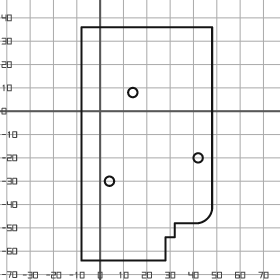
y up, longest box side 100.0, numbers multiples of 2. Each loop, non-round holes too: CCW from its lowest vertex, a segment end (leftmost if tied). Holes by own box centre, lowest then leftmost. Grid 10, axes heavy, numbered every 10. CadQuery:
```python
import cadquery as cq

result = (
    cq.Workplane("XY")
    .moveTo(-8.0, -64.0)
    .lineTo(28.0, -64.0)
    .lineTo(28.0, -54.0)
    .lineTo(32.0, -54.0)
    .lineTo(32.0, -48.0)
    .lineTo(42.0, -48.0)
    .threePointArc((46.0, -46.0), (48.0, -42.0))
    .lineTo(48.0, 36.0)
    .lineTo(-8.0, 36.0)
    .close()
    .moveTo(4.0, -30.0)
    .circle(2.0)
    .moveTo(42.0, -20.0)
    .circle(2.0)
    .moveTo(14.0, 8.0)
    .circle(2.0)
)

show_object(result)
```